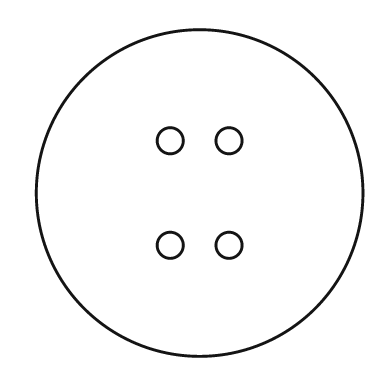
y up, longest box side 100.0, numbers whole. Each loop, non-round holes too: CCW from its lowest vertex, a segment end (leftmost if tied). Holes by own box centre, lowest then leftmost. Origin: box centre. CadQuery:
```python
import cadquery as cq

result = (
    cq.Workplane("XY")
    .moveTo(0.0, 0.0)
    .circle(50.0)
    .moveTo(-9.0, -16.0)
    .circle(4.0)
    .moveTo(9.0, -16.0)
    .circle(4.0)
    .moveTo(-9.0, 16.0)
    .circle(4.0)
    .moveTo(9.0, 16.0)
    .circle(4.0)
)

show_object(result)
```